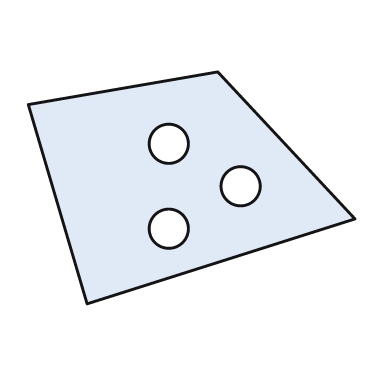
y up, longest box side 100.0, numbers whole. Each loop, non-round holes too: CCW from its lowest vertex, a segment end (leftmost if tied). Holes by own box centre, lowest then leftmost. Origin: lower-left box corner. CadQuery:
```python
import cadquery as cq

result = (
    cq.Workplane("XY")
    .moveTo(18.0, 0.0)
    .lineTo(100.0, 26.0)
    .lineTo(58.0, 71.0)
    .lineTo(0.0, 61.0)
    .close()
    .moveTo(43.0, 23.0)
    .circle(6.0)
    .moveTo(65.0, 36.0)
    .circle(6.0)
    .moveTo(43.0, 49.0)
    .circle(6.0)
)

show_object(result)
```